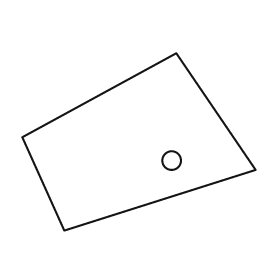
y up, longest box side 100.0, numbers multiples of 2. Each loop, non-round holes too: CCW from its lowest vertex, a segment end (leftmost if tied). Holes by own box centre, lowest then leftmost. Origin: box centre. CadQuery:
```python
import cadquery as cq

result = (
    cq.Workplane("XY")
    .moveTo(-32.0, -38.0)
    .lineTo(50.0, -12.0)
    .lineTo(16.0, 38.0)
    .lineTo(-50.0, 2.0)
    .close()
    .moveTo(14.0, -8.0)
    .circle(4.0)
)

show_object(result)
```